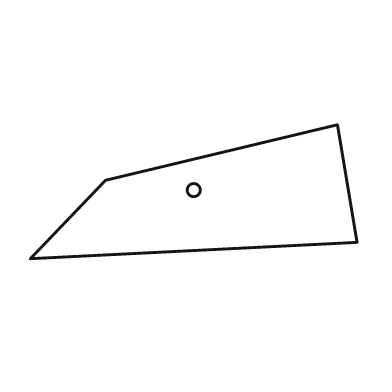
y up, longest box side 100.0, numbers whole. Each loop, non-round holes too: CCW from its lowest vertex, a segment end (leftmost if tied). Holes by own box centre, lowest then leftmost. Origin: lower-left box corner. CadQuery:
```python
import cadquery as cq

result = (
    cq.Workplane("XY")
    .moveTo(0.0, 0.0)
    .lineTo(100.0, 5.0)
    .lineTo(94.0, 41.0)
    .lineTo(23.0, 24.0)
    .close()
    .moveTo(50.0, 21.0)
    .circle(2.0)
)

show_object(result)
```